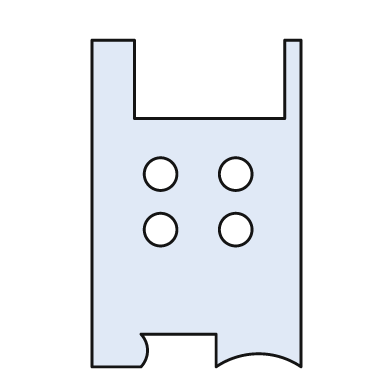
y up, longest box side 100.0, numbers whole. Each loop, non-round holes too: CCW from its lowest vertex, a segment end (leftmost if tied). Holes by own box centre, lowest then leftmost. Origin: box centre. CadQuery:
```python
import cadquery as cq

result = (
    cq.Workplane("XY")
    .moveTo(-32.0, -50.0)
    .lineTo(-17.0, -50.0)
    .threePointArc((-15.0, -45.0), (-17.0, -40.0))
    .lineTo(6.0, -40.0)
    .lineTo(6.0, -50.0)
    .threePointArc((19.0, -46.0), (32.0, -50.0))
    .lineTo(32.0, 50.0)
    .lineTo(27.0, 50.0)
    .lineTo(27.0, 26.0)
    .lineTo(-19.0, 26.0)
    .lineTo(-19.0, 50.0)
    .lineTo(-32.0, 50.0)
    .close()
    .moveTo(-11.0, -8.0)
    .circle(5.0)
    .moveTo(12.0, -8.0)
    .circle(5.0)
    .moveTo(-11.0, 9.0)
    .circle(5.0)
    .moveTo(12.0, 9.0)
    .circle(5.0)
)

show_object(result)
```